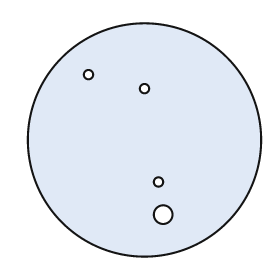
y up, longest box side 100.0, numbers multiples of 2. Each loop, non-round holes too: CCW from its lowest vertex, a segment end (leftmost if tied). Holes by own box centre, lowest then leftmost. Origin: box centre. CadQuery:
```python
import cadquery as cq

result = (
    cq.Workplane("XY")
    .moveTo(0.0, 0.0)
    .circle(50.0)
    .moveTo(8.0, -32.0)
    .circle(4.0)
    .moveTo(6.0, -18.0)
    .circle(2.0)
    .moveTo(0.0, 22.0)
    .circle(2.0)
    .moveTo(-24.0, 28.0)
    .circle(2.0)
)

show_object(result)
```